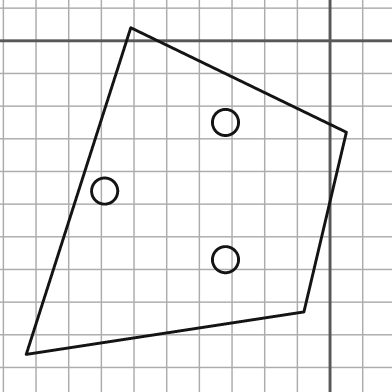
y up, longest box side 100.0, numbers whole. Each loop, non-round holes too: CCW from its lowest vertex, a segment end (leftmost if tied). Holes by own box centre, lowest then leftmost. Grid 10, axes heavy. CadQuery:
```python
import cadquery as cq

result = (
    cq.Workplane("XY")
    .moveTo(-93.0, -96.0)
    .lineTo(-8.0, -83.0)
    .lineTo(5.0, -28.0)
    .lineTo(-61.0, 4.0)
    .close()
    .moveTo(-32.0, -67.0)
    .circle(4.0)
    .moveTo(-69.0, -46.0)
    .circle(4.0)
    .moveTo(-32.0, -25.0)
    .circle(4.0)
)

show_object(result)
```